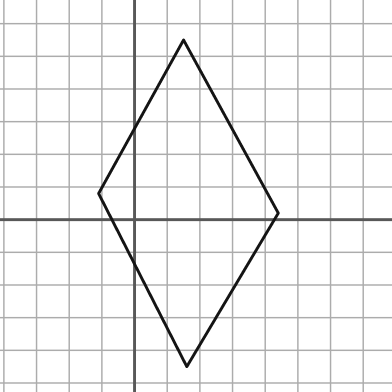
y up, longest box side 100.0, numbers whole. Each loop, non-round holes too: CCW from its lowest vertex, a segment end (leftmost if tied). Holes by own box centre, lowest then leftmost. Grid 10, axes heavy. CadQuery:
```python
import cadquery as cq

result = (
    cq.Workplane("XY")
    .moveTo(16.0, -45.0)
    .lineTo(44.0, 2.0)
    .lineTo(15.0, 55.0)
    .lineTo(-11.0, 8.0)
    .close()
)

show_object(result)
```